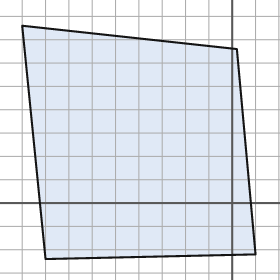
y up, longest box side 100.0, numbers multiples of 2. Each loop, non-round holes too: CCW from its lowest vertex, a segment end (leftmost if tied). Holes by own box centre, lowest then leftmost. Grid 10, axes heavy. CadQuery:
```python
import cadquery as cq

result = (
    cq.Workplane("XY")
    .moveTo(-80.0, -24.0)
    .lineTo(10.0, -22.0)
    .lineTo(2.0, 66.0)
    .lineTo(-90.0, 76.0)
    .close()
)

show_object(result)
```